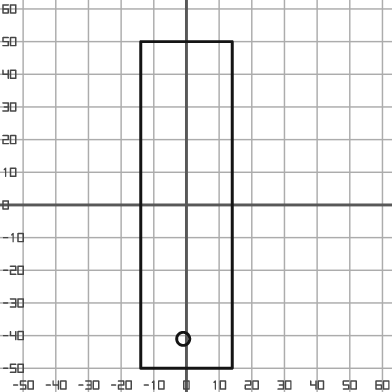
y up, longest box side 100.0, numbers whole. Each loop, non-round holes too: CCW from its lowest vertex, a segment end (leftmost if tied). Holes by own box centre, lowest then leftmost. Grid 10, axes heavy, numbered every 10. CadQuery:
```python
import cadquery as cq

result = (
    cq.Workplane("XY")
    .moveTo(-14.0, -50.0)
    .lineTo(14.0, -50.0)
    .lineTo(14.0, 50.0)
    .lineTo(-14.0, 50.0)
    .close()
    .moveTo(-1.0, -41.0)
    .circle(2.0)
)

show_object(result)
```